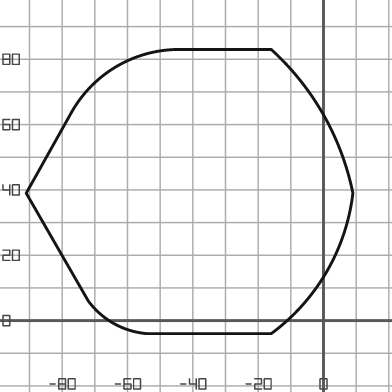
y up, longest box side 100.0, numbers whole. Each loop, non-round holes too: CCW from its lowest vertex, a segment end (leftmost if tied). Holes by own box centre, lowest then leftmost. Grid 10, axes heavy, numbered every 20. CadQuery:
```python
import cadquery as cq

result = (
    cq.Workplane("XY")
    .moveTo(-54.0, -4.0)
    .lineTo(-16.0, -4.0)
    .threePointArc((1.0, 15.0), (9.0, 39.0))
    .threePointArc((0.0, 63.0), (-16.0, 83.0))
    .lineTo(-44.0, 83.0)
    .threePointArc((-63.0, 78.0), (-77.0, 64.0))
    .lineTo(-91.0, 39.0)
    .lineTo(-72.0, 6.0)
    .threePointArc((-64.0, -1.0), (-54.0, -4.0))
    .close()
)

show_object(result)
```